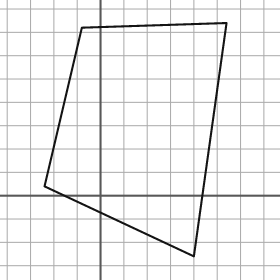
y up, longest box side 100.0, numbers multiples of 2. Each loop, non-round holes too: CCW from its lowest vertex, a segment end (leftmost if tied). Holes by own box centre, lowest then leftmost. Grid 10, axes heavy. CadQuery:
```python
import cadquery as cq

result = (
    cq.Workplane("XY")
    .moveTo(40.0, -26.0)
    .lineTo(54.0, 74.0)
    .lineTo(-8.0, 72.0)
    .lineTo(-24.0, 4.0)
    .close()
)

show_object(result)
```